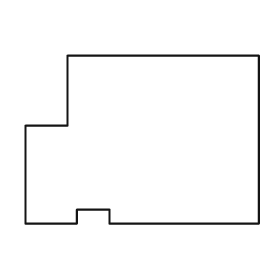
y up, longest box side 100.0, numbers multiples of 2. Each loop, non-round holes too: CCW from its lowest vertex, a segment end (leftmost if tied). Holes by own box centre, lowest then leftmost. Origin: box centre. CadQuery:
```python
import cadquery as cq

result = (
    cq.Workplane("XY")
    .moveTo(-50.0, -36.0)
    .lineTo(-28.0, -36.0)
    .lineTo(-28.0, -30.0)
    .lineTo(-14.0, -30.0)
    .lineTo(-14.0, -36.0)
    .lineTo(50.0, -36.0)
    .lineTo(50.0, 36.0)
    .lineTo(-32.0, 36.0)
    .lineTo(-32.0, 6.0)
    .lineTo(-50.0, 6.0)
    .close()
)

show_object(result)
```